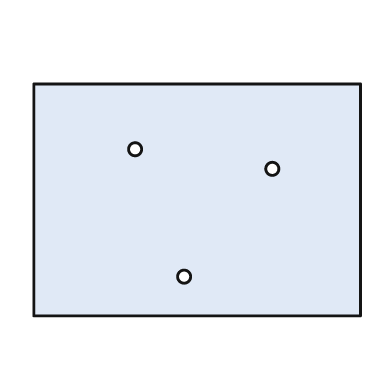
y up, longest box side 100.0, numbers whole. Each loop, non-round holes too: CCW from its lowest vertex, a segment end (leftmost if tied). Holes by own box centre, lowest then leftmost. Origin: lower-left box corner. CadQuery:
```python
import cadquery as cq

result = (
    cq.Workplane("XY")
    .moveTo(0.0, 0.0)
    .lineTo(100.0, 0.0)
    .lineTo(100.0, 71.0)
    .lineTo(0.0, 71.0)
    .close()
    .moveTo(46.0, 12.0)
    .circle(2.0)
    .moveTo(73.0, 45.0)
    .circle(2.0)
    .moveTo(31.0, 51.0)
    .circle(2.0)
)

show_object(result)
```